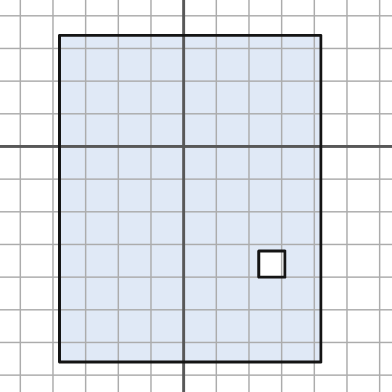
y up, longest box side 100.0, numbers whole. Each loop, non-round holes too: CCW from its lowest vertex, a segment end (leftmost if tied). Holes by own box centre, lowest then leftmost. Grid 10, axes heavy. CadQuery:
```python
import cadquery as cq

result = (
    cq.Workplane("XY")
    .moveTo(-38.0, -66.0)
    .lineTo(42.0, -66.0)
    .lineTo(42.0, 34.0)
    .lineTo(-38.0, 34.0)
    .close()
    .moveTo(23.0, -40.0)
    .lineTo(31.0, -40.0)
    .lineTo(31.0, -32.0)
    .lineTo(23.0, -32.0)
    .close()
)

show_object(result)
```